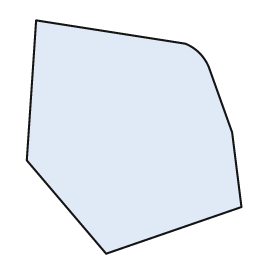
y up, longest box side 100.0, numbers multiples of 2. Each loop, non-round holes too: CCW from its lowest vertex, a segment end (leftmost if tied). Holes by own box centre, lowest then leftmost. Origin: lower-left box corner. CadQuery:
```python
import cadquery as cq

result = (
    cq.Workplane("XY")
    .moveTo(34.0, 0.0)
    .lineTo(92.0, 20.0)
    .lineTo(88.0, 52.0)
    .lineTo(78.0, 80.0)
    .threePointArc((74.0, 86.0), (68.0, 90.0))
    .lineTo(4.0, 100.0)
    .lineTo(0.0, 40.0)
    .close()
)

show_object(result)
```